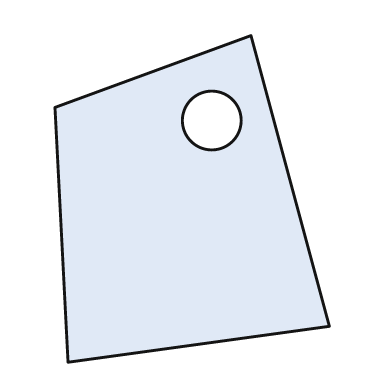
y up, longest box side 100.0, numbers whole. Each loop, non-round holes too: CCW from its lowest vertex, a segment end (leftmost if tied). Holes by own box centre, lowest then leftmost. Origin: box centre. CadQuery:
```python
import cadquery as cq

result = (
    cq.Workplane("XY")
    .moveTo(-38.0, -50.0)
    .lineTo(42.0, -39.0)
    .lineTo(18.0, 50.0)
    .lineTo(-42.0, 28.0)
    .close()
    .moveTo(6.0, 24.0)
    .circle(9.0)
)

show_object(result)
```